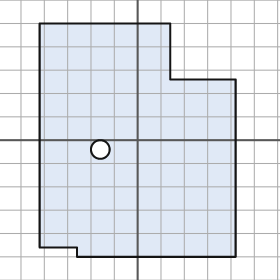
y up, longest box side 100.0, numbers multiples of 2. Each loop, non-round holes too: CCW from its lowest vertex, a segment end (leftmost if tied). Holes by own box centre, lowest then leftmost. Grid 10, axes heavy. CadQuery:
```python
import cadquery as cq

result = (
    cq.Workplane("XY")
    .moveTo(-26.0, -50.0)
    .lineTo(42.0, -50.0)
    .lineTo(42.0, 26.0)
    .lineTo(14.0, 26.0)
    .lineTo(14.0, 50.0)
    .lineTo(-42.0, 50.0)
    .lineTo(-42.0, -46.0)
    .lineTo(-26.0, -46.0)
    .close()
    .moveTo(-16.0, -4.0)
    .circle(4.0)
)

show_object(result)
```